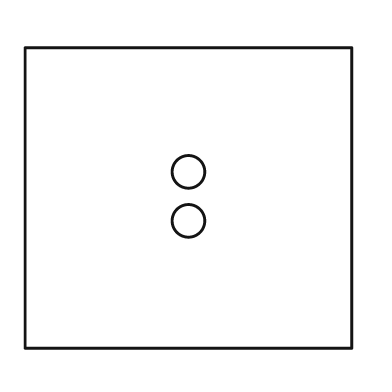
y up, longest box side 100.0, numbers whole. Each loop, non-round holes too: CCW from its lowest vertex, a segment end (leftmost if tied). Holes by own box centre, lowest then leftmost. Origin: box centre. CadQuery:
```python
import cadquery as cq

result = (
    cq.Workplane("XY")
    .moveTo(-50.0, -46.0)
    .lineTo(50.0, -46.0)
    .lineTo(50.0, 46.0)
    .lineTo(-50.0, 46.0)
    .close()
    .moveTo(0.0, -7.0)
    .circle(5.0)
    .moveTo(0.0, 8.0)
    .circle(5.0)
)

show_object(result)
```